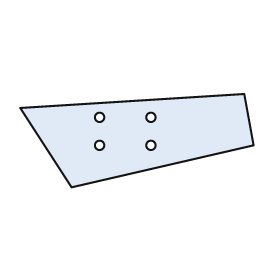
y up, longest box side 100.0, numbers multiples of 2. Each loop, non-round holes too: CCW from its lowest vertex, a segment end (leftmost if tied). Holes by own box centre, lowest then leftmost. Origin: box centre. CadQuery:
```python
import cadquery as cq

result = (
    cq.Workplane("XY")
    .moveTo(-28.0, -20.0)
    .lineTo(50.0, -2.0)
    .lineTo(46.0, 20.0)
    .lineTo(-50.0, 14.0)
    .close()
    .moveTo(-16.0, -2.0)
    .circle(2.0)
    .moveTo(6.0, -2.0)
    .circle(2.0)
    .moveTo(-16.0, 10.0)
    .circle(2.0)
    .moveTo(6.0, 10.0)
    .circle(2.0)
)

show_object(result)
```